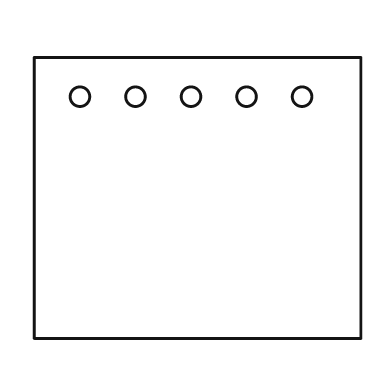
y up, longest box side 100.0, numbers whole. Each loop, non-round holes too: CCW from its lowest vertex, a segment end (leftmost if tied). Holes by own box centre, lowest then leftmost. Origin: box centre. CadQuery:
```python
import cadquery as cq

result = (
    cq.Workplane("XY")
    .moveTo(-50.0, -43.0)
    .lineTo(50.0, -43.0)
    .lineTo(50.0, 43.0)
    .lineTo(-50.0, 43.0)
    .close()
    .moveTo(-36.0, 31.0)
    .circle(3.0)
    .moveTo(-19.0, 31.0)
    .circle(3.0)
    .moveTo(-2.0, 31.0)
    .circle(3.0)
    .moveTo(15.0, 31.0)
    .circle(3.0)
    .moveTo(32.0, 31.0)
    .circle(3.0)
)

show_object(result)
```